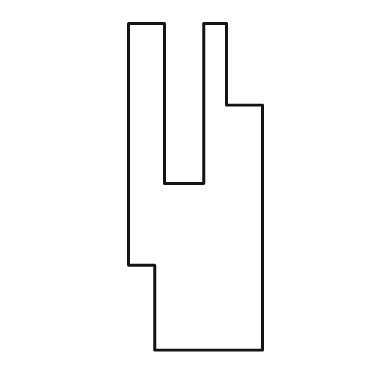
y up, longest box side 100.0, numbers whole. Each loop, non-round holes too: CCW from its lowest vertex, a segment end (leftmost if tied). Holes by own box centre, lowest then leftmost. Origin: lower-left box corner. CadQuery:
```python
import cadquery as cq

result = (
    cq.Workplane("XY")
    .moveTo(8.0, 0.0)
    .lineTo(41.0, 0.0)
    .lineTo(41.0, 75.0)
    .lineTo(30.0, 75.0)
    .lineTo(30.0, 100.0)
    .lineTo(23.0, 100.0)
    .lineTo(23.0, 51.0)
    .lineTo(11.0, 51.0)
    .lineTo(11.0, 100.0)
    .lineTo(0.0, 100.0)
    .lineTo(0.0, 26.0)
    .lineTo(8.0, 26.0)
    .close()
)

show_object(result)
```